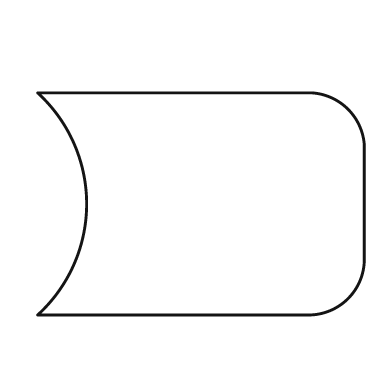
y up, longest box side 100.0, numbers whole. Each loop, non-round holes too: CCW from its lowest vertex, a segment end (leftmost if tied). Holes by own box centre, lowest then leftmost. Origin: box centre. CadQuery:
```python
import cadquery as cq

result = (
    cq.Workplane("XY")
    .moveTo(-50.0, -34.0)
    .lineTo(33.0, -34.0)
    .threePointArc((45.0, -29.0), (50.0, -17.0))
    .lineTo(50.0, 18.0)
    .threePointArc((45.0, 29.0), (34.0, 34.0))
    .lineTo(-50.0, 34.0)
    .threePointArc((-35.0, 0.0), (-50.0, -34.0))
    .close()
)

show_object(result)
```